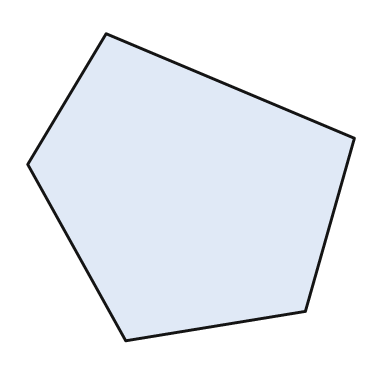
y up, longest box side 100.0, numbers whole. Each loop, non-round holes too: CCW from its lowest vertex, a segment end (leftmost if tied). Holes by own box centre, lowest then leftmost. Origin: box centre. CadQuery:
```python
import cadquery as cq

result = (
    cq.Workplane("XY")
    .moveTo(-20.0, -47.0)
    .lineTo(35.0, -38.0)
    .lineTo(50.0, 15.0)
    .lineTo(-26.0, 47.0)
    .lineTo(-50.0, 7.0)
    .close()
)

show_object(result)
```